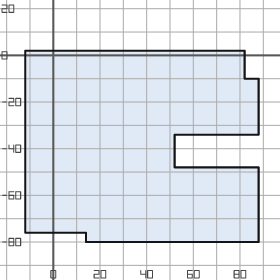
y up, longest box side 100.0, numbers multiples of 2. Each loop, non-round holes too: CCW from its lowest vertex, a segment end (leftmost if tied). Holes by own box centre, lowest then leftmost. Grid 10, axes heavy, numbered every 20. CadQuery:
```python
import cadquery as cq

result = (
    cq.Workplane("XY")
    .moveTo(14.0, -80.0)
    .lineTo(88.0, -80.0)
    .lineTo(88.0, -48.0)
    .lineTo(52.0, -48.0)
    .lineTo(52.0, -34.0)
    .lineTo(88.0, -34.0)
    .lineTo(88.0, -10.0)
    .lineTo(82.0, -10.0)
    .lineTo(82.0, 2.0)
    .lineTo(-12.0, 2.0)
    .lineTo(-12.0, -76.0)
    .lineTo(14.0, -76.0)
    .close()
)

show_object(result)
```